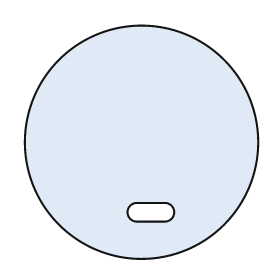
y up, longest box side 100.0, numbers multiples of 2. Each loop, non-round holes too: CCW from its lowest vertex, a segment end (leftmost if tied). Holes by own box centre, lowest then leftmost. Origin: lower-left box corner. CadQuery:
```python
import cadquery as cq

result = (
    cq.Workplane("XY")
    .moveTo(50.0, 50.0)
    .circle(50.0)
    .moveTo(48.0, 16.0)
    .lineTo(60.0, 16.0)
    .threePointArc((64.0, 20.0), (60.0, 24.0))
    .lineTo(48.0, 24.0)
    .threePointArc((44.0, 20.0), (48.0, 16.0))
    .close()
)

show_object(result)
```